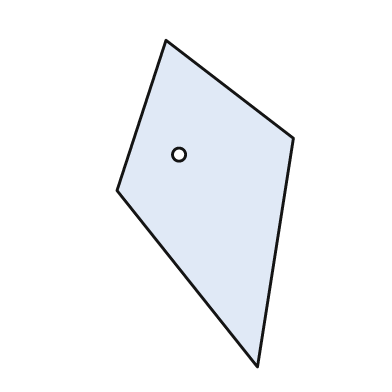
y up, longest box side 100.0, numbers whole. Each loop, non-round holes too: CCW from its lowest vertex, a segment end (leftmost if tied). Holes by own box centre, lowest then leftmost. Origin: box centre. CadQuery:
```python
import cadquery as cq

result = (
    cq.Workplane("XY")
    .moveTo(16.0, -50.0)
    .lineTo(27.0, 20.0)
    .lineTo(-12.0, 50.0)
    .lineTo(-27.0, 4.0)
    .close()
    .moveTo(-8.0, 15.0)
    .circle(2.0)
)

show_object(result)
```